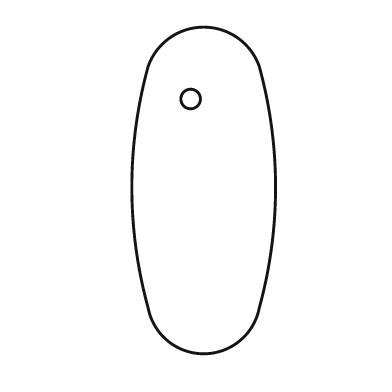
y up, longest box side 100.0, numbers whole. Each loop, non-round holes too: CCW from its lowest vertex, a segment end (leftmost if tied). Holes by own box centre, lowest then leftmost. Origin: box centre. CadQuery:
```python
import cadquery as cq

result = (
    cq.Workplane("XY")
    .moveTo(-17.0, -36.0)
    .threePointArc((0.0, -50.0), (17.0, -36.0))
    .threePointArc((22.0, 1.0), (17.0, 38.0))
    .threePointArc((0.0, 50.0), (-17.0, 38.0))
    .threePointArc((-22.0, 1.0), (-17.0, -36.0))
    .close()
    .moveTo(-4.0, 28.0)
    .circle(3.0)
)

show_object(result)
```